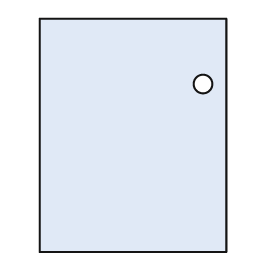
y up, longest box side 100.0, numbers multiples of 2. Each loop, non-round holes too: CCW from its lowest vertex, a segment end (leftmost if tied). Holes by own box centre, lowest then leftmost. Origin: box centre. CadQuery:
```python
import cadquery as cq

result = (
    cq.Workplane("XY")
    .moveTo(-40.0, -50.0)
    .lineTo(40.0, -50.0)
    .lineTo(40.0, 50.0)
    .lineTo(-40.0, 50.0)
    .close()
    .moveTo(30.0, 22.0)
    .circle(4.0)
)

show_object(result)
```